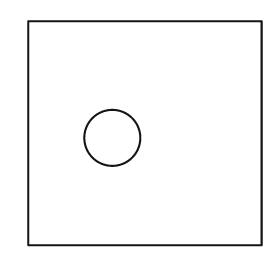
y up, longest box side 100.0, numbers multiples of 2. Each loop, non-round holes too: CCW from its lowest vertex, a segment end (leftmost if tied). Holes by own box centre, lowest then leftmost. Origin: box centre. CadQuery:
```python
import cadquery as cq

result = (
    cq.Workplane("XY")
    .moveTo(-50.0, -48.0)
    .lineTo(50.0, -48.0)
    .lineTo(50.0, 48.0)
    .lineTo(-50.0, 48.0)
    .close()
    .moveTo(-14.0, -2.0)
    .circle(12.0)
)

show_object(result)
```